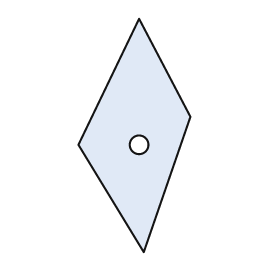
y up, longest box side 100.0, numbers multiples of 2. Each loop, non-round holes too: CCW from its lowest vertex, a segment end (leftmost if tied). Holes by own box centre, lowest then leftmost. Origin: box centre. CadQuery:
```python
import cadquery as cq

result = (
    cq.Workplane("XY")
    .moveTo(4.0, -50.0)
    .lineTo(24.0, 8.0)
    .lineTo(2.0, 50.0)
    .lineTo(-24.0, -4.0)
    .close()
    .moveTo(2.0, -4.0)
    .circle(4.0)
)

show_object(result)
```